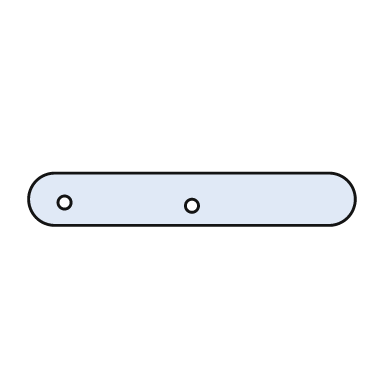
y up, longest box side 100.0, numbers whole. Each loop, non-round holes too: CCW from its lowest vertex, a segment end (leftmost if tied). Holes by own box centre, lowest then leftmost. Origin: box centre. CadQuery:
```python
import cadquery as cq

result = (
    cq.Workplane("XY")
    .moveTo(-42.0, -8.0)
    .lineTo(42.0, -8.0)
    .threePointArc((50.0, 0.0), (42.0, 8.0))
    .lineTo(-42.0, 8.0)
    .threePointArc((-50.0, 0.0), (-42.0, -8.0))
    .close()
    .moveTo(0.0, -2.0)
    .circle(2.0)
    .moveTo(-39.0, -1.0)
    .circle(2.0)
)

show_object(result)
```